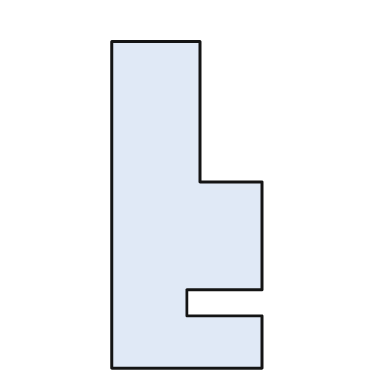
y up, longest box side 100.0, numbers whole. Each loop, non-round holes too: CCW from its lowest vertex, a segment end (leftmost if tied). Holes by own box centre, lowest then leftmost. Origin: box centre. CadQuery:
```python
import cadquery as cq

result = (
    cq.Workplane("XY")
    .moveTo(-23.0, -50.0)
    .lineTo(23.0, -50.0)
    .lineTo(23.0, -34.0)
    .lineTo(0.0, -34.0)
    .lineTo(0.0, -26.0)
    .lineTo(23.0, -26.0)
    .lineTo(23.0, 7.0)
    .lineTo(4.0, 7.0)
    .lineTo(4.0, 50.0)
    .lineTo(-23.0, 50.0)
    .close()
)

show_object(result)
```